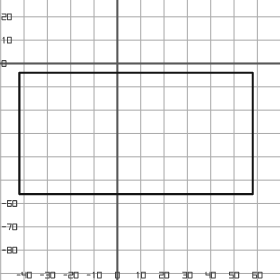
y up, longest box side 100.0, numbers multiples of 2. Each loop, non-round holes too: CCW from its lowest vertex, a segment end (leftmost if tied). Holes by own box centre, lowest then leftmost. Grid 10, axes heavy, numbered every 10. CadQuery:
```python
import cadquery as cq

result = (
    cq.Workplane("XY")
    .moveTo(-42.0, -56.0)
    .lineTo(58.0, -56.0)
    .lineTo(58.0, -4.0)
    .lineTo(-42.0, -4.0)
    .close()
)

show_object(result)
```